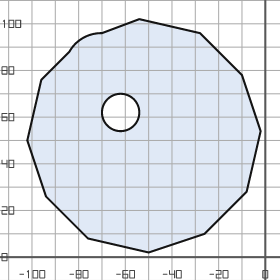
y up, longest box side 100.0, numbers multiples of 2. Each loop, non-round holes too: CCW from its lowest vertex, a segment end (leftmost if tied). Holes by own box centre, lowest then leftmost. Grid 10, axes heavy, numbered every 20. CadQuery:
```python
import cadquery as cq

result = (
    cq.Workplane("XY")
    .moveTo(-50.0, 2.0)
    .lineTo(-26.0, 10.0)
    .lineTo(-8.0, 28.0)
    .lineTo(-2.0, 54.0)
    .lineTo(-10.0, 78.0)
    .lineTo(-28.0, 96.0)
    .lineTo(-54.0, 102.0)
    .lineTo(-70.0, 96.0)
    .threePointArc((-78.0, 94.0), (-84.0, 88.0))
    .lineTo(-96.0, 76.0)
    .lineTo(-102.0, 50.0)
    .lineTo(-94.0, 26.0)
    .lineTo(-76.0, 8.0)
    .close()
    .moveTo(-62.0, 62.0)
    .circle(8.0)
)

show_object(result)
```